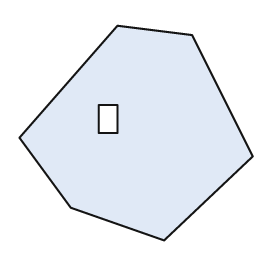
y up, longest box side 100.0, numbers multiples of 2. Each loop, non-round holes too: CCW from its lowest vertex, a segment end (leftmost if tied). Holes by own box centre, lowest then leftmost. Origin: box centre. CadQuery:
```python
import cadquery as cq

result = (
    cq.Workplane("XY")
    .moveTo(12.0, -46.0)
    .lineTo(50.0, -10.0)
    .lineTo(24.0, 42.0)
    .lineTo(-8.0, 46.0)
    .lineTo(-50.0, -2.0)
    .lineTo(-28.0, -32.0)
    .close()
    .moveTo(-16.0, 0.0)
    .lineTo(-8.0, 0.0)
    .lineTo(-8.0, 12.0)
    .lineTo(-16.0, 12.0)
    .close()
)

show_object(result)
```